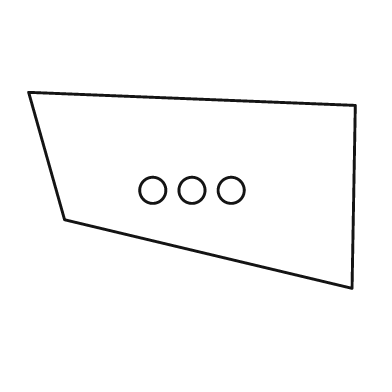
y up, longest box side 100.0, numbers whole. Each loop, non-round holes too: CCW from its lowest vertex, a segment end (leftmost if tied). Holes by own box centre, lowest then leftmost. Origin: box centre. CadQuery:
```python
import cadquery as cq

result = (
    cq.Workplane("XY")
    .moveTo(49.0, -30.0)
    .lineTo(50.0, 26.0)
    .lineTo(-50.0, 30.0)
    .lineTo(-39.0, -9.0)
    .close()
    .moveTo(-12.0, 0.0)
    .circle(4.0)
    .moveTo(0.0, 0.0)
    .circle(4.0)
    .moveTo(12.0, 0.0)
    .circle(4.0)
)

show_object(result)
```